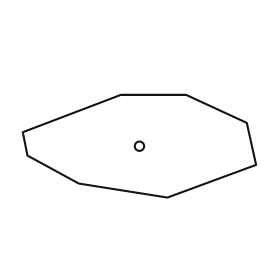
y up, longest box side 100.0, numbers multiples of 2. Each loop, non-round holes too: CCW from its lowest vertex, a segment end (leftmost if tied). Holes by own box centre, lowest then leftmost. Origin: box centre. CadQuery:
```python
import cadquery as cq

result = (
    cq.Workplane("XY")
    .moveTo(12.0, -22.0)
    .lineTo(50.0, -8.0)
    .lineTo(46.0, 10.0)
    .lineTo(20.0, 22.0)
    .lineTo(-8.0, 22.0)
    .lineTo(-50.0, 6.0)
    .lineTo(-48.0, -4.0)
    .lineTo(-26.0, -16.0)
    .close()
    .moveTo(0.0, 0.0)
    .circle(2.0)
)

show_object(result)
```